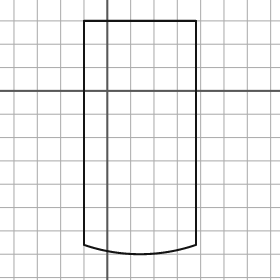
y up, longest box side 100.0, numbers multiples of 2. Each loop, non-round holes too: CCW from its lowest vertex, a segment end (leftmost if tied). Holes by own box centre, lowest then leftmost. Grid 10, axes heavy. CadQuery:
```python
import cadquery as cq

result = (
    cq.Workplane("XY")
    .moveTo(-10.0, -66.0)
    .threePointArc((14.0, -70.0), (38.0, -66.0))
    .lineTo(38.0, 30.0)
    .lineTo(-10.0, 30.0)
    .close()
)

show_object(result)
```